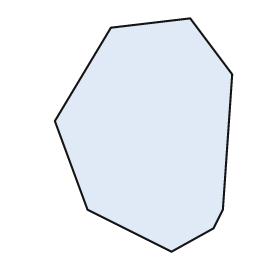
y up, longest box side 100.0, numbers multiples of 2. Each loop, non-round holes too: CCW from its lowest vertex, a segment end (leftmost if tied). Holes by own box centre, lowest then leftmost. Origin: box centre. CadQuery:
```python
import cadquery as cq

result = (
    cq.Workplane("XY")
    .moveTo(12.0, -50.0)
    .lineTo(30.0, -40.0)
    .lineTo(34.0, -32.0)
    .lineTo(38.0, 26.0)
    .lineTo(20.0, 50.0)
    .lineTo(-14.0, 46.0)
    .lineTo(-38.0, 6.0)
    .lineTo(-24.0, -32.0)
    .close()
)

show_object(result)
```